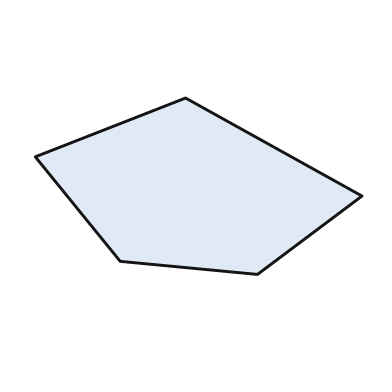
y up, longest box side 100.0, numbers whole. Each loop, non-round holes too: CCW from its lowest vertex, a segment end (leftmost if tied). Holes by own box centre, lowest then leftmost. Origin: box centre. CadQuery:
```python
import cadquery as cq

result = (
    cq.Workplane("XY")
    .moveTo(18.0, -27.0)
    .lineTo(50.0, -3.0)
    .lineTo(-4.0, 27.0)
    .lineTo(-50.0, 9.0)
    .lineTo(-24.0, -23.0)
    .close()
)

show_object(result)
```